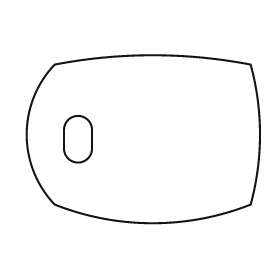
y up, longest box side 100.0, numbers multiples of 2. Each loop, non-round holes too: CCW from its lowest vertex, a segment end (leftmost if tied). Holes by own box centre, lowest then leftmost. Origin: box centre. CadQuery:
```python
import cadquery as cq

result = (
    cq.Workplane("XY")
    .moveTo(-38.0, -28.0)
    .threePointArc((4.0, -36.0), (46.0, -28.0))
    .threePointArc((50.0, 2.0), (46.0, 32.0))
    .threePointArc((4.0, 36.0), (-38.0, 32.0))
    .threePointArc((-50.0, 2.0), (-38.0, -28.0))
    .close()
    .moveTo(-34.0, -4.0)
    .threePointArc((-28.0, -10.0), (-22.0, -4.0))
    .lineTo(-22.0, 4.0)
    .threePointArc((-28.0, 10.0), (-34.0, 4.0))
    .close()
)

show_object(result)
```